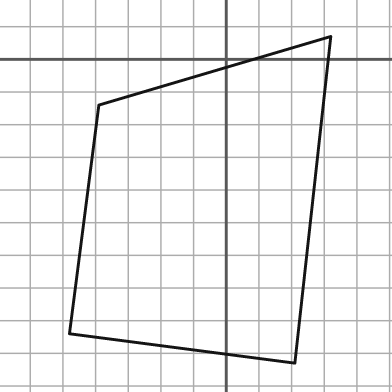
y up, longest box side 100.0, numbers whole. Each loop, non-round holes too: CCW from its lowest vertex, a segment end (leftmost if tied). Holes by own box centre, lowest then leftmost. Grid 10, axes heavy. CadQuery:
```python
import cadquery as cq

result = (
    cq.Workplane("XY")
    .moveTo(21.0, -93.0)
    .lineTo(32.0, 7.0)
    .lineTo(-39.0, -14.0)
    .lineTo(-48.0, -84.0)
    .close()
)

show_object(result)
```